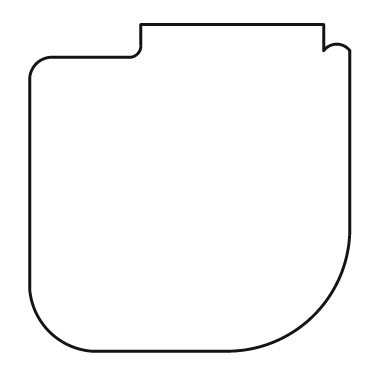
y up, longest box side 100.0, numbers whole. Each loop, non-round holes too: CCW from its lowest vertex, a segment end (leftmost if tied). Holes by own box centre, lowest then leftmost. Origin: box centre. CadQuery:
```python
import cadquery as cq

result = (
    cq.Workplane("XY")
    .moveTo(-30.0, -50.0)
    .lineTo(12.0, -50.0)
    .threePointArc((38.0, -39.0), (49.0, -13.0))
    .lineTo(49.0, 42.0)
    .threePointArc((45.0, 44.0), (41.0, 42.0))
    .lineTo(41.0, 50.0)
    .lineTo(-15.0, 50.0)
    .lineTo(-15.0, 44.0)
    .threePointArc((-16.0, 41.0), (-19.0, 40.0))
    .lineTo(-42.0, 40.0)
    .threePointArc((-47.0, 38.0), (-49.0, 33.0))
    .lineTo(-49.0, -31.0)
    .threePointArc((-43.0, -44.0), (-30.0, -50.0))
    .close()
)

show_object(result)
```